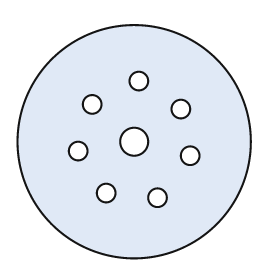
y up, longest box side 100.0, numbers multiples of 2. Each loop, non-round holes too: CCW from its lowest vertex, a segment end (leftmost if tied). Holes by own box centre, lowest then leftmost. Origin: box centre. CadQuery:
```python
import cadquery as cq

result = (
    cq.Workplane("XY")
    .moveTo(0.0, 0.0)
    .circle(50.0)
    .moveTo(10.0, -24.0)
    .circle(4.0)
    .moveTo(-12.0, -22.0)
    .circle(4.0)
    .moveTo(24.0, -6.0)
    .circle(4.0)
    .moveTo(-24.0, -4.0)
    .circle(4.0)
    .moveTo(0.0, 0.0)
    .circle(6.0)
    .moveTo(20.0, 14.0)
    .circle(4.0)
    .moveTo(-18.0, 16.0)
    .circle(4.0)
    .moveTo(2.0, 26.0)
    .circle(4.0)
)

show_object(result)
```